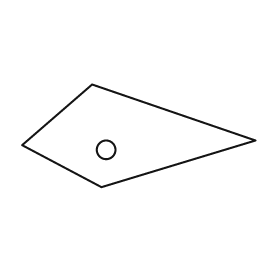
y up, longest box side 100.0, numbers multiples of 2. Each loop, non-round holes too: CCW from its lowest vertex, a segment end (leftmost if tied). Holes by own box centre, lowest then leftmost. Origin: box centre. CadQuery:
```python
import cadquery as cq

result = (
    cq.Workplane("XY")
    .moveTo(-16.0, -22.0)
    .lineTo(50.0, -2.0)
    .lineTo(-20.0, 22.0)
    .lineTo(-50.0, -4.0)
    .close()
    .moveTo(-14.0, -6.0)
    .circle(4.0)
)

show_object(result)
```